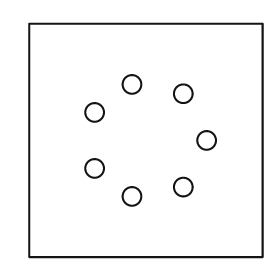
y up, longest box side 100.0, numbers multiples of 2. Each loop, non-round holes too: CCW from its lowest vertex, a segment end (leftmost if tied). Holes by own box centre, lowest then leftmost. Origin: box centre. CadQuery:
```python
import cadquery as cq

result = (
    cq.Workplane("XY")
    .moveTo(-50.0, -50.0)
    .lineTo(50.0, -50.0)
    .lineTo(50.0, 50.0)
    .lineTo(-50.0, 50.0)
    .close()
    .moveTo(-6.0, -24.0)
    .circle(4.0)
    .moveTo(16.0, -20.0)
    .circle(4.0)
    .moveTo(-22.0, -12.0)
    .circle(4.0)
    .moveTo(26.0, 0.0)
    .circle(4.0)
    .moveTo(-22.0, 12.0)
    .circle(4.0)
    .moveTo(16.0, 20.0)
    .circle(4.0)
    .moveTo(-6.0, 24.0)
    .circle(4.0)
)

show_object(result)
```